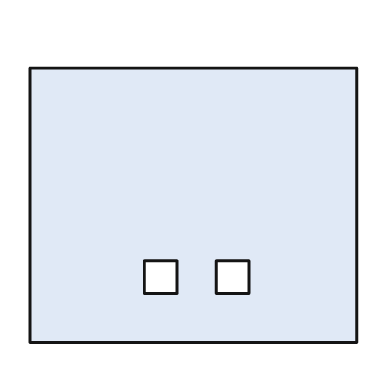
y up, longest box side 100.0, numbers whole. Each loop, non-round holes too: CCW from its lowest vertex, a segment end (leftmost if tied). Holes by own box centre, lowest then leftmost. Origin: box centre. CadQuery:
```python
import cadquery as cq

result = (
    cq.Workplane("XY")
    .moveTo(-50.0, -42.0)
    .lineTo(50.0, -42.0)
    .lineTo(50.0, 42.0)
    .lineTo(-50.0, 42.0)
    .close()
    .moveTo(-15.0, -27.0)
    .lineTo(-5.0, -27.0)
    .lineTo(-5.0, -17.0)
    .lineTo(-15.0, -17.0)
    .close()
    .moveTo(7.0, -27.0)
    .lineTo(17.0, -27.0)
    .lineTo(17.0, -17.0)
    .lineTo(7.0, -17.0)
    .close()
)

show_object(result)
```